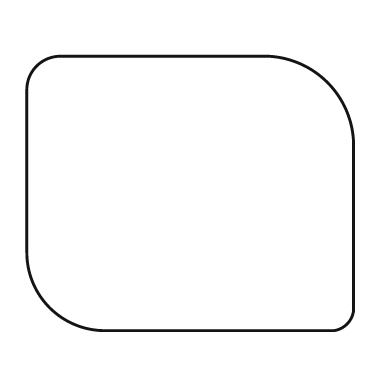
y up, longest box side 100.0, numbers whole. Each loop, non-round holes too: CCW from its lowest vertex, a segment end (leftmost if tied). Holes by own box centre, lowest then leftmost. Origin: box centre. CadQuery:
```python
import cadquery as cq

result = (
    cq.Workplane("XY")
    .moveTo(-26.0, -42.0)
    .lineTo(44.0, -42.0)
    .threePointArc((48.0, -40.0), (50.0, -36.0))
    .lineTo(50.0, 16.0)
    .threePointArc((42.0, 34.0), (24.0, 42.0))
    .lineTo(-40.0, 42.0)
    .threePointArc((-47.0, 39.0), (-50.0, 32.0))
    .lineTo(-50.0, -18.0)
    .threePointArc((-43.0, -35.0), (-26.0, -42.0))
    .close()
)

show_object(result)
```